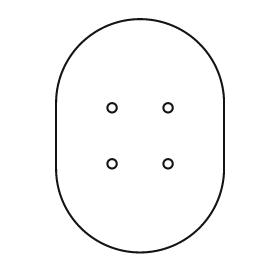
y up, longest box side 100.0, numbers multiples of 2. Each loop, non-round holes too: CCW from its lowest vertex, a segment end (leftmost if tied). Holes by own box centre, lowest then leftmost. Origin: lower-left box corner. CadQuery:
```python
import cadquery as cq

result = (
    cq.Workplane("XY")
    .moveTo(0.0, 36.0)
    .threePointArc((36.0, 0.0), (72.0, 36.0))
    .lineTo(72.0, 64.0)
    .threePointArc((36.0, 100.0), (0.0, 64.0))
    .close()
    .moveTo(24.0, 38.0)
    .circle(2.0)
    .moveTo(48.0, 38.0)
    .circle(2.0)
    .moveTo(24.0, 62.0)
    .circle(2.0)
    .moveTo(48.0, 62.0)
    .circle(2.0)
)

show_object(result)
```